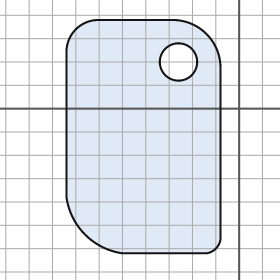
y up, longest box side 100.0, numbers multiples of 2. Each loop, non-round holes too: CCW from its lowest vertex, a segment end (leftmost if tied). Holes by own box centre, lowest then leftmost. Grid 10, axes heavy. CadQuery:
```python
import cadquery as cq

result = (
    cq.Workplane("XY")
    .moveTo(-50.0, -62.0)
    .lineTo(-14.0, -62.0)
    .threePointArc((-10.0, -60.0), (-8.0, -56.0))
    .lineTo(-8.0, 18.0)
    .threePointArc((-14.0, 32.0), (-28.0, 38.0))
    .lineTo(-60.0, 38.0)
    .threePointArc((-70.0, 34.0), (-74.0, 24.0))
    .lineTo(-74.0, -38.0)
    .threePointArc((-66.0, -54.0), (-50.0, -62.0))
    .close()
    .moveTo(-26.0, 20.0)
    .circle(8.0)
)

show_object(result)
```